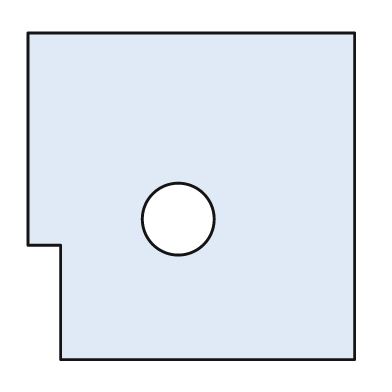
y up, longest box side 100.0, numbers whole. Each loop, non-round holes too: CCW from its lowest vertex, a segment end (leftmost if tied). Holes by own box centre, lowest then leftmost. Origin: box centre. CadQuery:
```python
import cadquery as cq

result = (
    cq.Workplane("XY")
    .moveTo(-40.0, -50.0)
    .lineTo(50.0, -50.0)
    .lineTo(50.0, 50.0)
    .lineTo(-50.0, 50.0)
    .lineTo(-50.0, -15.0)
    .lineTo(-40.0, -15.0)
    .close()
    .moveTo(-4.0, -7.0)
    .circle(11.0)
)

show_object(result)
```